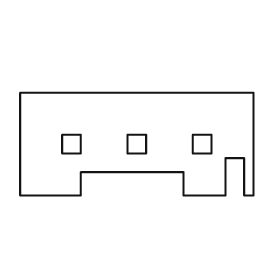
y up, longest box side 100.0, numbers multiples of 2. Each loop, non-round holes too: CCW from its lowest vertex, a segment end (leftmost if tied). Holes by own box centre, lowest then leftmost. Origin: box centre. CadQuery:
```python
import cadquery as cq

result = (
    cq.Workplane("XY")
    .moveTo(-50.0, -22.0)
    .lineTo(-24.0, -22.0)
    .lineTo(-24.0, -12.0)
    .lineTo(20.0, -12.0)
    .lineTo(20.0, -22.0)
    .lineTo(38.0, -22.0)
    .lineTo(38.0, -6.0)
    .lineTo(46.0, -6.0)
    .lineTo(46.0, -22.0)
    .lineTo(50.0, -22.0)
    .lineTo(50.0, 22.0)
    .lineTo(-50.0, 22.0)
    .close()
    .moveTo(-32.0, -4.0)
    .lineTo(-24.0, -4.0)
    .lineTo(-24.0, 4.0)
    .lineTo(-32.0, 4.0)
    .close()
    .moveTo(-4.0, -4.0)
    .lineTo(4.0, -4.0)
    .lineTo(4.0, 4.0)
    .lineTo(-4.0, 4.0)
    .close()
    .moveTo(24.0, -4.0)
    .lineTo(32.0, -4.0)
    .lineTo(32.0, 4.0)
    .lineTo(24.0, 4.0)
    .close()
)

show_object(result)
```